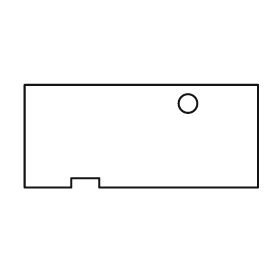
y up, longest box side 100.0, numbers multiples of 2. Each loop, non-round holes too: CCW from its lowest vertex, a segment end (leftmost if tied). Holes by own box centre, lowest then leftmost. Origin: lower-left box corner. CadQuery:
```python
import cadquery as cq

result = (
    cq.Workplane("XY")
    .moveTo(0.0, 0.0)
    .lineTo(20.0, 0.0)
    .lineTo(20.0, 4.0)
    .lineTo(32.0, 4.0)
    .lineTo(32.0, 0.0)
    .lineTo(100.0, 0.0)
    .lineTo(100.0, 44.0)
    .lineTo(0.0, 44.0)
    .close()
    .moveTo(70.0, 36.0)
    .circle(4.0)
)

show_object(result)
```